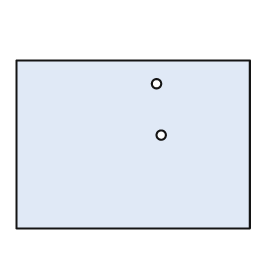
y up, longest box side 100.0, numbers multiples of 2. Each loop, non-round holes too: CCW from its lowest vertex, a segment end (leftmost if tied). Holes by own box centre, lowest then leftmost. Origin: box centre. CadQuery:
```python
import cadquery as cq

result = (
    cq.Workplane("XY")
    .moveTo(-50.0, -36.0)
    .lineTo(50.0, -36.0)
    .lineTo(50.0, 36.0)
    .lineTo(-50.0, 36.0)
    .close()
    .moveTo(12.0, 4.0)
    .circle(2.0)
    .moveTo(10.0, 26.0)
    .circle(2.0)
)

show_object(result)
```